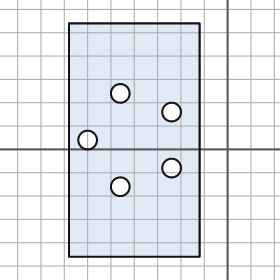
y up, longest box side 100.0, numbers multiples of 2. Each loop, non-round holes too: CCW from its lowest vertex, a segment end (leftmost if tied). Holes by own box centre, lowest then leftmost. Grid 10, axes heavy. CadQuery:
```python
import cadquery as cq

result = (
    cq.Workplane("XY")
    .moveTo(-68.0, -46.0)
    .lineTo(-12.0, -46.0)
    .lineTo(-12.0, 54.0)
    .lineTo(-68.0, 54.0)
    .close()
    .moveTo(-46.0, -16.0)
    .circle(4.0)
    .moveTo(-24.0, -8.0)
    .circle(4.0)
    .moveTo(-60.0, 4.0)
    .circle(4.0)
    .moveTo(-24.0, 16.0)
    .circle(4.0)
    .moveTo(-46.0, 24.0)
    .circle(4.0)
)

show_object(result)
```